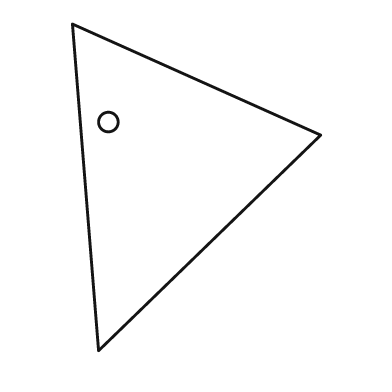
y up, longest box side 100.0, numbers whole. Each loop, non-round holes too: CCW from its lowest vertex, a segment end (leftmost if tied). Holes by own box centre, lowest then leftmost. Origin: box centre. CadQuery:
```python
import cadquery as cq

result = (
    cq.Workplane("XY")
    .moveTo(-30.0, -50.0)
    .lineTo(38.0, 16.0)
    .lineTo(-38.0, 50.0)
    .close()
    .moveTo(-27.0, 20.0)
    .circle(3.0)
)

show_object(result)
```